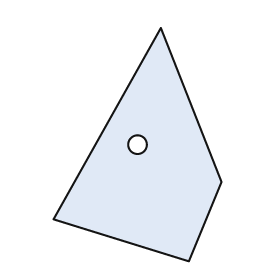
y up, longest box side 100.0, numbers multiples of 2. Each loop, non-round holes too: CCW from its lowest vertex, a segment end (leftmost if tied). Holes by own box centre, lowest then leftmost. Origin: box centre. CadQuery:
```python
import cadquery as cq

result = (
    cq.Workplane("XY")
    .moveTo(22.0, -50.0)
    .lineTo(36.0, -16.0)
    .lineTo(10.0, 50.0)
    .lineTo(-36.0, -32.0)
    .close()
    .moveTo(0.0, 0.0)
    .circle(4.0)
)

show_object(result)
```